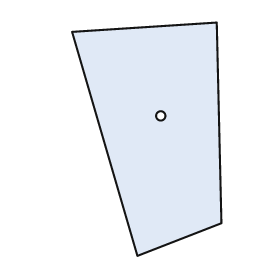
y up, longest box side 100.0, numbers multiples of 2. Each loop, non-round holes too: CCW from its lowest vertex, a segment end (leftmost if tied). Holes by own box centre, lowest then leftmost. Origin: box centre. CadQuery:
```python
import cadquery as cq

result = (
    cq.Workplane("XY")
    .moveTo(-4.0, -50.0)
    .lineTo(32.0, -36.0)
    .lineTo(30.0, 50.0)
    .lineTo(-32.0, 46.0)
    .close()
    .moveTo(6.0, 10.0)
    .circle(2.0)
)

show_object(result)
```